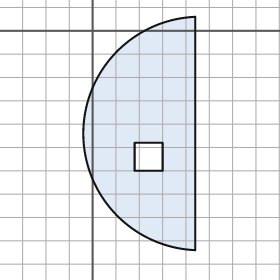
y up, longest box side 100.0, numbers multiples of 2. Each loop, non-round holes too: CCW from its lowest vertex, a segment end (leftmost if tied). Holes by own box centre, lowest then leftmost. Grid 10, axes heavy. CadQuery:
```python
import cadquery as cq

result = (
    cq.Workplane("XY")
    .moveTo(44.0, -94.0)
    .lineTo(44.0, 6.0)
    .threePointArc((-4.0, -44.0), (44.0, -94.0))
    .close()
    .moveTo(18.0, -60.0)
    .lineTo(30.0, -60.0)
    .lineTo(30.0, -48.0)
    .lineTo(18.0, -48.0)
    .close()
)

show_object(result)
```